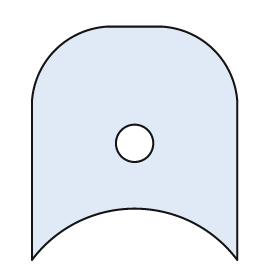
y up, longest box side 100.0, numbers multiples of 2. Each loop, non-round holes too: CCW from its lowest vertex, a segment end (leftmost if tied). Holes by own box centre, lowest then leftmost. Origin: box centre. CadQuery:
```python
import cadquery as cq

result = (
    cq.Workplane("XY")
    .moveTo(-44.0, -50.0)
    .threePointArc((0.0, -28.0), (44.0, -50.0))
    .lineTo(44.0, 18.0)
    .threePointArc((34.0, 40.0), (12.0, 50.0))
    .lineTo(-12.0, 50.0)
    .threePointArc((-34.0, 40.0), (-44.0, 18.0))
    .close()
    .moveTo(0.0, 0.0)
    .circle(8.0)
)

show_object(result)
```